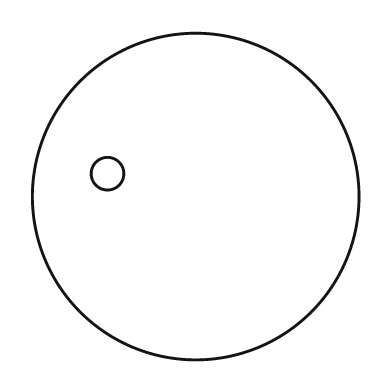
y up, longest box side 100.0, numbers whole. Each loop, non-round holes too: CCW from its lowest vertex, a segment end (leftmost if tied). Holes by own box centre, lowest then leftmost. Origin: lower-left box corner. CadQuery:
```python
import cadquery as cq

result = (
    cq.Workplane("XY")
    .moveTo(50.0, 50.0)
    .circle(50.0)
    .moveTo(23.0, 57.0)
    .circle(5.0)
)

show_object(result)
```